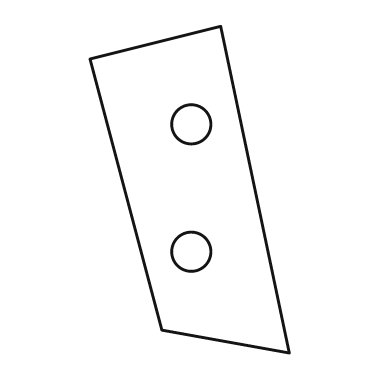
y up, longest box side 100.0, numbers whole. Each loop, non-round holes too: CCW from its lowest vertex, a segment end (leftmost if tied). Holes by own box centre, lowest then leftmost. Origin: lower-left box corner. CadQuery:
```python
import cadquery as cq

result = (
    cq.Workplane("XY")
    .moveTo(61.0, 0.0)
    .lineTo(40.0, 100.0)
    .lineTo(0.0, 90.0)
    .lineTo(22.0, 7.0)
    .close()
    .moveTo(31.0, 31.0)
    .circle(6.0)
    .moveTo(31.0, 70.0)
    .circle(6.0)
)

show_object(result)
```